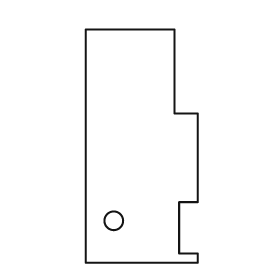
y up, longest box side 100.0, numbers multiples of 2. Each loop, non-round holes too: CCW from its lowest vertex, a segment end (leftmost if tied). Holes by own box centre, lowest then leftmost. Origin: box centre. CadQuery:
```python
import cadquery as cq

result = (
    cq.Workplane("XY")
    .moveTo(-24.0, -50.0)
    .lineTo(24.0, -50.0)
    .lineTo(24.0, -46.0)
    .lineTo(16.0, -46.0)
    .lineTo(16.0, -24.0)
    .lineTo(24.0, -24.0)
    .lineTo(24.0, 14.0)
    .lineTo(14.0, 14.0)
    .lineTo(14.0, 50.0)
    .lineTo(-24.0, 50.0)
    .close()
    .moveTo(-12.0, -32.0)
    .circle(4.0)
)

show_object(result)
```